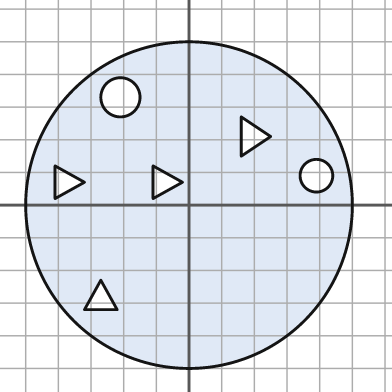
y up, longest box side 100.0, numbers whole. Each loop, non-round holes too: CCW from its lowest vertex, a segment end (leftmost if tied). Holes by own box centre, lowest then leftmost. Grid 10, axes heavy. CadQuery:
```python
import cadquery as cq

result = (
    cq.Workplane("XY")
    .moveTo(0.0, 0.0)
    .circle(50.0)
    .moveTo(-32.0, -32.0)
    .lineTo(-22.0, -32.0)
    .lineTo(-27.0, -23.0)
    .close()
    .moveTo(-41.0, 2.0)
    .lineTo(-32.0, 7.0)
    .lineTo(-41.0, 12.0)
    .close()
    .moveTo(-11.0, 2.0)
    .lineTo(-2.0, 7.0)
    .lineTo(-11.0, 12.0)
    .close()
    .moveTo(39.0, 9.0)
    .circle(5.0)
    .moveTo(16.0, 15.0)
    .lineTo(25.0, 21.0)
    .lineTo(16.0, 27.0)
    .close()
    .moveTo(-21.0, 33.0)
    .circle(6.0)
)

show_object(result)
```